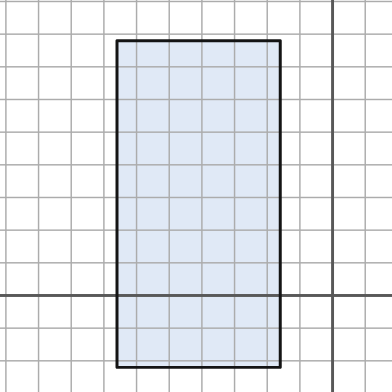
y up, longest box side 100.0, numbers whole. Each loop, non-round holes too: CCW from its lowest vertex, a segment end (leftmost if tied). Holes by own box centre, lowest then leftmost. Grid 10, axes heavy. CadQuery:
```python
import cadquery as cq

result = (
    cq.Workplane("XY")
    .moveTo(-66.0, -22.0)
    .lineTo(-16.0, -22.0)
    .lineTo(-16.0, 78.0)
    .lineTo(-66.0, 78.0)
    .close()
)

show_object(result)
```